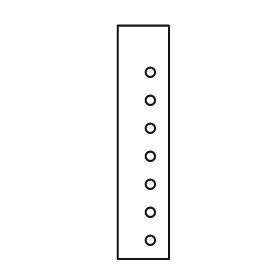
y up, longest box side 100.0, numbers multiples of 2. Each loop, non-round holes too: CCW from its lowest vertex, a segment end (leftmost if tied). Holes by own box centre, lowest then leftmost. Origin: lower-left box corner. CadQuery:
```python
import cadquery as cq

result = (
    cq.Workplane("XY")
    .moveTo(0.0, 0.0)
    .lineTo(22.0, 0.0)
    .lineTo(22.0, 100.0)
    .lineTo(0.0, 100.0)
    .close()
    .moveTo(14.0, 8.0)
    .circle(2.0)
    .moveTo(14.0, 20.0)
    .circle(2.0)
    .moveTo(14.0, 32.0)
    .circle(2.0)
    .moveTo(14.0, 44.0)
    .circle(2.0)
    .moveTo(14.0, 56.0)
    .circle(2.0)
    .moveTo(14.0, 68.0)
    .circle(2.0)
    .moveTo(14.0, 80.0)
    .circle(2.0)
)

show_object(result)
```